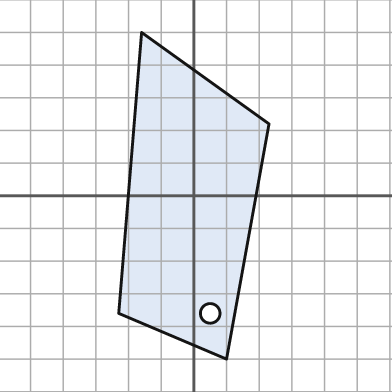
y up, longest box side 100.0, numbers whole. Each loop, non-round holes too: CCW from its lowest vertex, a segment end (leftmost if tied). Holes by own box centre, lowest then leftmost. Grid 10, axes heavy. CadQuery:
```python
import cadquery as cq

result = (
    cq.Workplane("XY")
    .moveTo(10.0, -50.0)
    .lineTo(23.0, 22.0)
    .lineTo(-16.0, 50.0)
    .lineTo(-23.0, -36.0)
    .close()
    .moveTo(5.0, -36.0)
    .circle(3.0)
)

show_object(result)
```